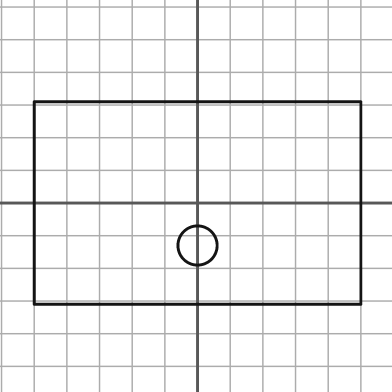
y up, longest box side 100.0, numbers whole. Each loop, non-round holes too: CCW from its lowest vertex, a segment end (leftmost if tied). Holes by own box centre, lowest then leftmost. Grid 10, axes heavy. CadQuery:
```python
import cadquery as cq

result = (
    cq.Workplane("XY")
    .moveTo(-50.0, -31.0)
    .lineTo(50.0, -31.0)
    .lineTo(50.0, 31.0)
    .lineTo(-50.0, 31.0)
    .close()
    .moveTo(0.0, -13.0)
    .circle(6.0)
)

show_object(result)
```